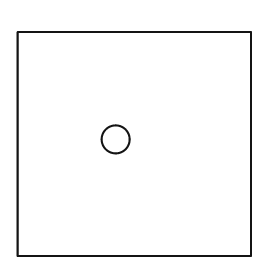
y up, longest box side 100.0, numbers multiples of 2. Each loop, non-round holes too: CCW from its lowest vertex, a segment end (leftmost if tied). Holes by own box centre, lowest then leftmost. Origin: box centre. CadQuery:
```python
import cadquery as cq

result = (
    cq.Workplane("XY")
    .moveTo(-50.0, -48.0)
    .lineTo(50.0, -48.0)
    .lineTo(50.0, 48.0)
    .lineTo(-50.0, 48.0)
    .close()
    .moveTo(-8.0, 2.0)
    .circle(6.0)
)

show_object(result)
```